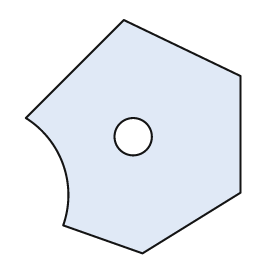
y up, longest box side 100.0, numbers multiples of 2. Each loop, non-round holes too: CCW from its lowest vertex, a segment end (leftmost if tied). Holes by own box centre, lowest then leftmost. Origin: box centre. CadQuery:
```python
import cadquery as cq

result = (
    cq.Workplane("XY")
    .moveTo(4.0, -50.0)
    .lineTo(46.0, -24.0)
    .lineTo(46.0, 26.0)
    .lineTo(-4.0, 50.0)
    .lineTo(-46.0, 8.0)
    .threePointArc((-30.0, -12.0), (-30.0, -38.0))
    .close()
    .moveTo(0.0, 0.0)
    .circle(8.0)
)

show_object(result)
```